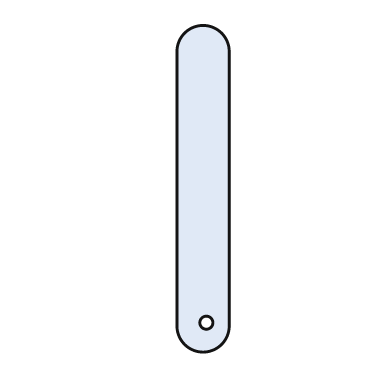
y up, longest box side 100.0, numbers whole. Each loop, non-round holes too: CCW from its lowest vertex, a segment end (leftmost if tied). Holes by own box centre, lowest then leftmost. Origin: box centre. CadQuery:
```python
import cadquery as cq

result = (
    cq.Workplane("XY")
    .moveTo(-8.0, -42.0)
    .threePointArc((0.0, -50.0), (8.0, -42.0))
    .lineTo(8.0, 42.0)
    .threePointArc((0.0, 50.0), (-8.0, 42.0))
    .close()
    .moveTo(1.0, -41.0)
    .circle(2.0)
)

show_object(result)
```